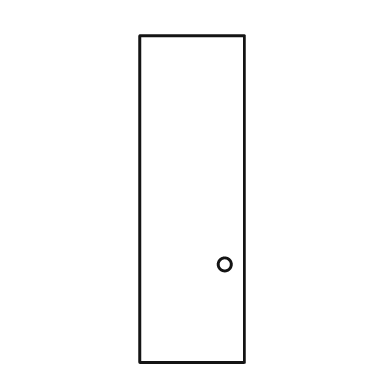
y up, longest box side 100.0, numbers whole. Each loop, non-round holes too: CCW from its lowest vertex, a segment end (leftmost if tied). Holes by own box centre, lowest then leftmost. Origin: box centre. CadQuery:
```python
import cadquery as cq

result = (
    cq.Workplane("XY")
    .moveTo(-16.0, -50.0)
    .lineTo(16.0, -50.0)
    .lineTo(16.0, 50.0)
    .lineTo(-16.0, 50.0)
    .close()
    .moveTo(10.0, -20.0)
    .circle(2.0)
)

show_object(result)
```